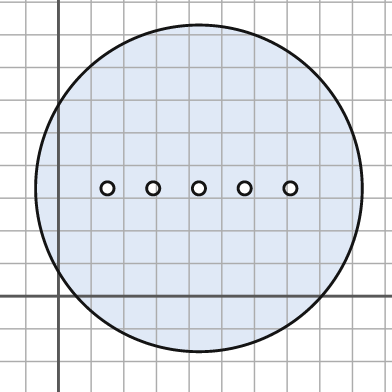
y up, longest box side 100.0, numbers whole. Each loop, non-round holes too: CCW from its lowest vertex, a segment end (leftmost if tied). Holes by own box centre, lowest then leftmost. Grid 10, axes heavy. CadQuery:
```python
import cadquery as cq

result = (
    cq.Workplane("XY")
    .moveTo(43.0, 33.0)
    .circle(50.0)
    .moveTo(15.0, 33.0)
    .circle(2.0)
    .moveTo(29.0, 33.0)
    .circle(2.0)
    .moveTo(43.0, 33.0)
    .circle(2.0)
    .moveTo(57.0, 33.0)
    .circle(2.0)
    .moveTo(71.0, 33.0)
    .circle(2.0)
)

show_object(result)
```